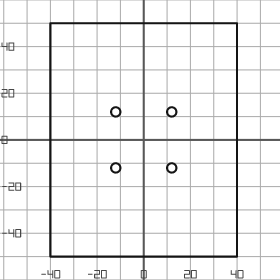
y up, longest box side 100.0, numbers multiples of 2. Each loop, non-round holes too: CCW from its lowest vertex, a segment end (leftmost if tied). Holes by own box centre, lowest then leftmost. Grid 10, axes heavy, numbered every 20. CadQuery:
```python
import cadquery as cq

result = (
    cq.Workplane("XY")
    .moveTo(-40.0, -50.0)
    .lineTo(40.0, -50.0)
    .lineTo(40.0, 50.0)
    .lineTo(-40.0, 50.0)
    .close()
    .moveTo(-12.0, -12.0)
    .circle(2.0)
    .moveTo(12.0, -12.0)
    .circle(2.0)
    .moveTo(-12.0, 12.0)
    .circle(2.0)
    .moveTo(12.0, 12.0)
    .circle(2.0)
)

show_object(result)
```